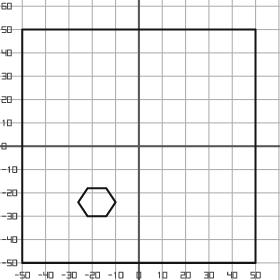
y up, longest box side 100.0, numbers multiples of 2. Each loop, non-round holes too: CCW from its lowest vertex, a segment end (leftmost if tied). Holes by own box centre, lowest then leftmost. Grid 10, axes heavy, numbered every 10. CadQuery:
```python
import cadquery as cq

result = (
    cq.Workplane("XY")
    .moveTo(-50.0, -50.0)
    .lineTo(50.0, -50.0)
    .lineTo(50.0, 50.0)
    .lineTo(-50.0, 50.0)
    .close()
    .moveTo(-22.0, -30.0)
    .lineTo(-14.0, -30.0)
    .lineTo(-10.0, -24.0)
    .lineTo(-14.0, -18.0)
    .lineTo(-22.0, -18.0)
    .lineTo(-26.0, -24.0)
    .close()
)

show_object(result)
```